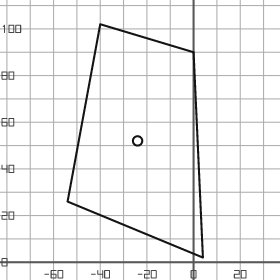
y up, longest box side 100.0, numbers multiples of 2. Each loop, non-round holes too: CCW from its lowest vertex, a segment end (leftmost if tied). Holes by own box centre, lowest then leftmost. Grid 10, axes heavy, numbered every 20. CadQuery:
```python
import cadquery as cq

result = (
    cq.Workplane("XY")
    .moveTo(4.0, 2.0)
    .lineTo(0.0, 90.0)
    .lineTo(-40.0, 102.0)
    .lineTo(-54.0, 26.0)
    .close()
    .moveTo(-24.0, 52.0)
    .circle(2.0)
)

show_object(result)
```